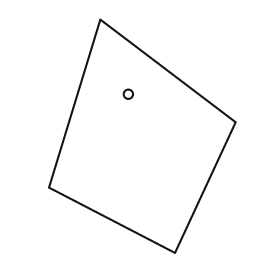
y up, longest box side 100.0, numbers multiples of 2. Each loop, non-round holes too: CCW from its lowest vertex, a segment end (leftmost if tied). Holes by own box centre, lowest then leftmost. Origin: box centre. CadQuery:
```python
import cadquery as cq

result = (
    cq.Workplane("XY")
    .moveTo(14.0, -50.0)
    .lineTo(40.0, 6.0)
    .lineTo(-18.0, 50.0)
    .lineTo(-40.0, -22.0)
    .close()
    .moveTo(-6.0, 18.0)
    .circle(2.0)
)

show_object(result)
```